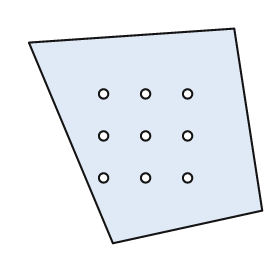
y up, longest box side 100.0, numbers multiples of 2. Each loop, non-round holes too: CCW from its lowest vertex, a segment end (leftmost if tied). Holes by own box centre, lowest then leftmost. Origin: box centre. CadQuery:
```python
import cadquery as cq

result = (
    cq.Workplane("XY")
    .moveTo(-14.0, -46.0)
    .lineTo(50.0, -32.0)
    .lineTo(38.0, 46.0)
    .lineTo(-50.0, 40.0)
    .close()
    .moveTo(-18.0, -18.0)
    .circle(2.0)
    .moveTo(0.0, -18.0)
    .circle(2.0)
    .moveTo(18.0, -18.0)
    .circle(2.0)
    .moveTo(-18.0, 0.0)
    .circle(2.0)
    .moveTo(0.0, 0.0)
    .circle(2.0)
    .moveTo(18.0, 0.0)
    .circle(2.0)
    .moveTo(-18.0, 18.0)
    .circle(2.0)
    .moveTo(0.0, 18.0)
    .circle(2.0)
    .moveTo(18.0, 18.0)
    .circle(2.0)
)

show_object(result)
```